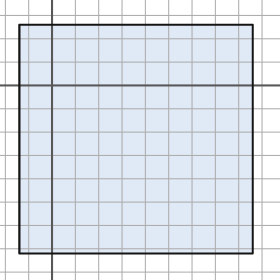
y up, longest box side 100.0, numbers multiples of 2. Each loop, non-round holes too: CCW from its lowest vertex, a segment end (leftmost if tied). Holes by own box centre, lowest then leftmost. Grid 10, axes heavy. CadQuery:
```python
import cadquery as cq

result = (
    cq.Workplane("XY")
    .moveTo(-14.0, -72.0)
    .lineTo(86.0, -72.0)
    .lineTo(86.0, 26.0)
    .lineTo(-14.0, 26.0)
    .close()
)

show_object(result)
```